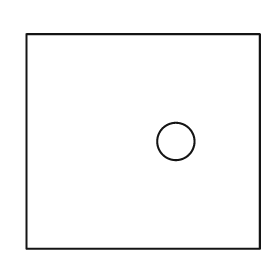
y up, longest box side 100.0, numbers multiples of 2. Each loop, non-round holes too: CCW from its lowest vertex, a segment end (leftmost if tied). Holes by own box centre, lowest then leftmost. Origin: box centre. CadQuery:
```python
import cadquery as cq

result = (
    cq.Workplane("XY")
    .moveTo(-50.0, -46.0)
    .lineTo(50.0, -46.0)
    .lineTo(50.0, 46.0)
    .lineTo(-50.0, 46.0)
    .close()
    .moveTo(14.0, 0.0)
    .circle(8.0)
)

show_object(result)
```